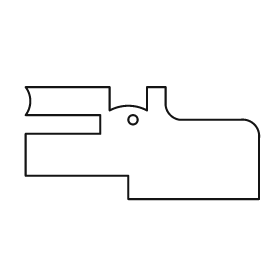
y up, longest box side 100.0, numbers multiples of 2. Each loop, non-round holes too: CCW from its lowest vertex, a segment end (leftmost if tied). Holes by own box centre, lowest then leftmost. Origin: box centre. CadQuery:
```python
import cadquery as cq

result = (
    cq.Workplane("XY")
    .moveTo(-6.0, -24.0)
    .lineTo(50.0, -24.0)
    .lineTo(50.0, 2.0)
    .threePointArc((48.0, 8.0), (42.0, 10.0))
    .lineTo(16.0, 10.0)
    .threePointArc((12.0, 12.0), (10.0, 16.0))
    .lineTo(10.0, 24.0)
    .lineTo(2.0, 24.0)
    .lineTo(2.0, 14.0)
    .threePointArc((-6.0, 16.0), (-14.0, 14.0))
    .lineTo(-14.0, 24.0)
    .lineTo(-50.0, 24.0)
    .threePointArc((-48.0, 18.0), (-50.0, 12.0))
    .lineTo(-18.0, 12.0)
    .lineTo(-18.0, 4.0)
    .lineTo(-50.0, 4.0)
    .lineTo(-50.0, -14.0)
    .lineTo(-6.0, -14.0)
    .close()
    .moveTo(-4.0, 10.0)
    .circle(2.0)
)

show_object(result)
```